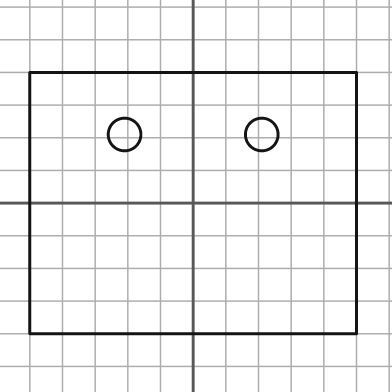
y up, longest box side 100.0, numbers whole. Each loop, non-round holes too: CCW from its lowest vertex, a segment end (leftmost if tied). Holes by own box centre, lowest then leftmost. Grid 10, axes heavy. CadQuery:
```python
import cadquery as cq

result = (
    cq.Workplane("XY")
    .moveTo(-50.0, -40.0)
    .lineTo(50.0, -40.0)
    .lineTo(50.0, 40.0)
    .lineTo(-50.0, 40.0)
    .close()
    .moveTo(-21.0, 21.0)
    .circle(5.0)
    .moveTo(21.0, 21.0)
    .circle(5.0)
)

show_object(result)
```